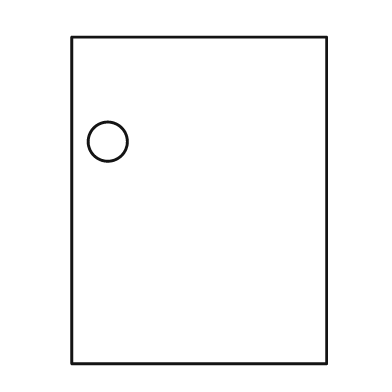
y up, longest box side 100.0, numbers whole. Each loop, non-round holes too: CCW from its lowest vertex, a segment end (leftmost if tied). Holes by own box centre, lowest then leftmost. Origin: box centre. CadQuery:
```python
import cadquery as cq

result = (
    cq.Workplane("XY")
    .moveTo(-39.0, -50.0)
    .lineTo(39.0, -50.0)
    .lineTo(39.0, 50.0)
    .lineTo(-39.0, 50.0)
    .close()
    .moveTo(-28.0, 18.0)
    .circle(6.0)
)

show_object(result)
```